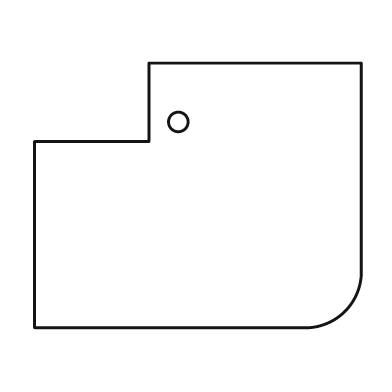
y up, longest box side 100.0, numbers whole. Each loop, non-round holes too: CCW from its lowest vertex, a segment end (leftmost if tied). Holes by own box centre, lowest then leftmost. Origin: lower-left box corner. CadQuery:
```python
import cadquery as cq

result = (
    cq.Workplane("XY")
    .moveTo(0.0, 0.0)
    .lineTo(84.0, 0.0)
    .threePointArc((95.0, 5.0), (100.0, 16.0))
    .lineTo(100.0, 81.0)
    .lineTo(35.0, 81.0)
    .lineTo(35.0, 57.0)
    .lineTo(0.0, 57.0)
    .close()
    .moveTo(44.0, 63.0)
    .circle(3.0)
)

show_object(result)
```